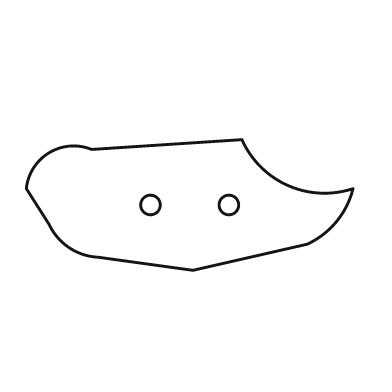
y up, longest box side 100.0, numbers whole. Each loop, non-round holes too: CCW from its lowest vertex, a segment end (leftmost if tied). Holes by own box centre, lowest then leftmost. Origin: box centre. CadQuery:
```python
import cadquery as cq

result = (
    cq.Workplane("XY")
    .moveTo(1.0, -20.0)
    .lineTo(36.0, -12.0)
    .threePointArc((45.0, -5.0), (50.0, 5.0))
    .threePointArc((30.0, 6.0), (16.0, 20.0))
    .lineTo(-30.0, 17.0)
    .threePointArc((-43.0, 16.0), (-50.0, 5.0))
    .lineTo(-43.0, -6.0)
    .threePointArc((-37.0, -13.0), (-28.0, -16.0))
    .close()
    .moveTo(-12.0, 0.0)
    .circle(3.0)
    .moveTo(12.0, 0.0)
    .circle(3.0)
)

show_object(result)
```